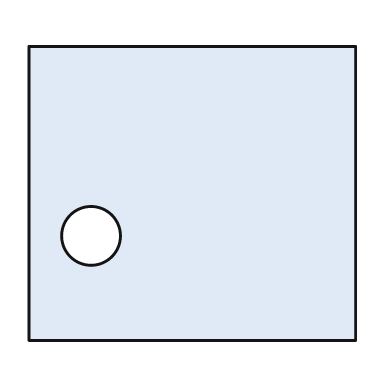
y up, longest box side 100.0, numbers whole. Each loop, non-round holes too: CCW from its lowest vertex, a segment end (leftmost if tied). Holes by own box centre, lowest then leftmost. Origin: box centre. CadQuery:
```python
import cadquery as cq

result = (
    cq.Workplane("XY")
    .moveTo(-50.0, -45.0)
    .lineTo(50.0, -45.0)
    .lineTo(50.0, 45.0)
    .lineTo(-50.0, 45.0)
    .close()
    .moveTo(-31.0, -13.0)
    .circle(9.0)
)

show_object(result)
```